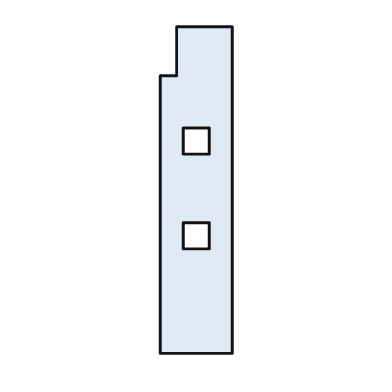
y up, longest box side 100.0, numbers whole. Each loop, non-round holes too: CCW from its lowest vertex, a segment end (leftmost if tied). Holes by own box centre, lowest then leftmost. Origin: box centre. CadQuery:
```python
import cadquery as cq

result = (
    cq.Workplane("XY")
    .moveTo(-11.0, -50.0)
    .lineTo(11.0, -50.0)
    .lineTo(11.0, 50.0)
    .lineTo(-6.0, 50.0)
    .lineTo(-6.0, 35.0)
    .lineTo(-11.0, 35.0)
    .close()
    .moveTo(-4.0, -18.0)
    .lineTo(4.0, -18.0)
    .lineTo(4.0, -10.0)
    .lineTo(-4.0, -10.0)
    .close()
    .moveTo(-4.0, 11.0)
    .lineTo(4.0, 11.0)
    .lineTo(4.0, 19.0)
    .lineTo(-4.0, 19.0)
    .close()
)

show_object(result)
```